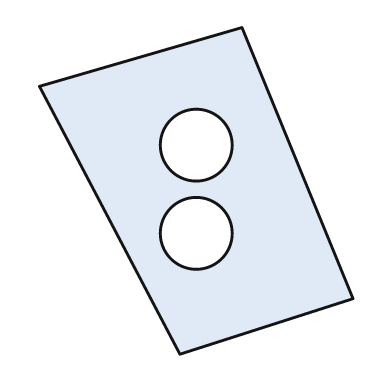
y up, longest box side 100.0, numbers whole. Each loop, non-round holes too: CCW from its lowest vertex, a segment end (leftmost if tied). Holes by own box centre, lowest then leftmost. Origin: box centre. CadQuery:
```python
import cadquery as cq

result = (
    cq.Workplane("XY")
    .moveTo(-5.0, -50.0)
    .lineTo(48.0, -33.0)
    .lineTo(14.0, 50.0)
    .lineTo(-48.0, 32.0)
    .close()
    .moveTo(0.0, -13.0)
    .circle(11.0)
    .moveTo(0.0, 14.0)
    .circle(11.0)
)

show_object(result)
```